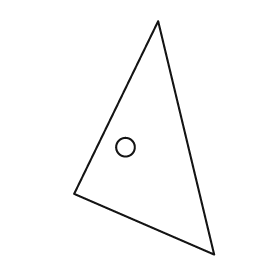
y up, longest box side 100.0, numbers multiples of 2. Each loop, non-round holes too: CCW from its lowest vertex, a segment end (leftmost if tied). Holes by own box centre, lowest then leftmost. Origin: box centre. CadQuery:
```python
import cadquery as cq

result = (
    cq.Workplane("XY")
    .moveTo(30.0, -50.0)
    .lineTo(6.0, 50.0)
    .lineTo(-30.0, -24.0)
    .close()
    .moveTo(-8.0, -4.0)
    .circle(4.0)
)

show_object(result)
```